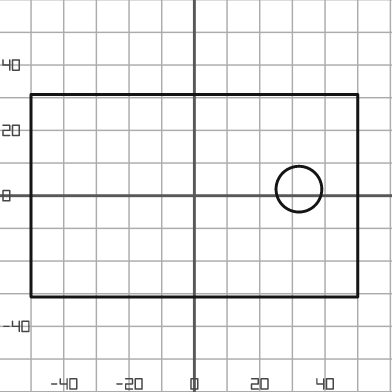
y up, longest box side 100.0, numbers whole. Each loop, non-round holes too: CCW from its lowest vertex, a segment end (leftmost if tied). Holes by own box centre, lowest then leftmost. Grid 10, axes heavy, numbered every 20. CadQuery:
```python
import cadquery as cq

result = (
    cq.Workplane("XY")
    .moveTo(-50.0, -31.0)
    .lineTo(50.0, -31.0)
    .lineTo(50.0, 31.0)
    .lineTo(-50.0, 31.0)
    .close()
    .moveTo(32.0, 2.0)
    .circle(7.0)
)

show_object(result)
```